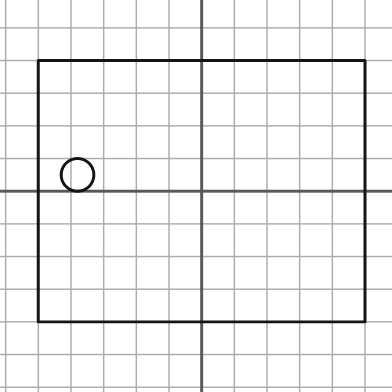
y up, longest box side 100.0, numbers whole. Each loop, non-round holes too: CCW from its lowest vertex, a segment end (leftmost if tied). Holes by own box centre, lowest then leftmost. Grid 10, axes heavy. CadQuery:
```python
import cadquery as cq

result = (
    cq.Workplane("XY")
    .moveTo(-50.0, -40.0)
    .lineTo(50.0, -40.0)
    .lineTo(50.0, 40.0)
    .lineTo(-50.0, 40.0)
    .close()
    .moveTo(-38.0, 5.0)
    .circle(5.0)
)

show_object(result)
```